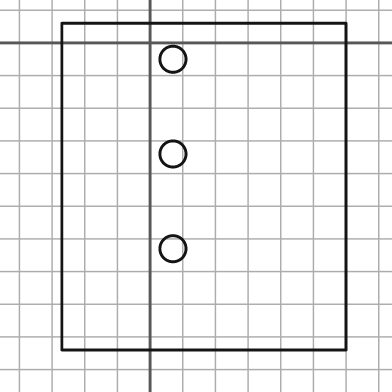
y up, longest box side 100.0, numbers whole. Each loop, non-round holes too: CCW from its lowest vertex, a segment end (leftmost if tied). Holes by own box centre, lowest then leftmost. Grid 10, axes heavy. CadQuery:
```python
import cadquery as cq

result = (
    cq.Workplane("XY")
    .moveTo(-27.0, -94.0)
    .lineTo(60.0, -94.0)
    .lineTo(60.0, 6.0)
    .lineTo(-27.0, 6.0)
    .close()
    .moveTo(7.0, -63.0)
    .circle(4.0)
    .moveTo(7.0, -34.0)
    .circle(4.0)
    .moveTo(7.0, -5.0)
    .circle(4.0)
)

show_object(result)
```